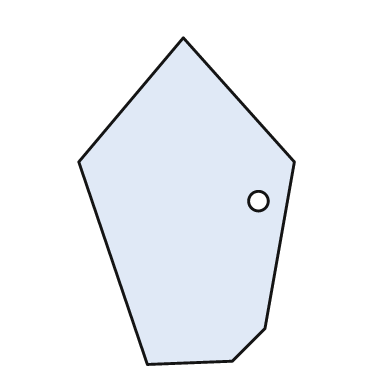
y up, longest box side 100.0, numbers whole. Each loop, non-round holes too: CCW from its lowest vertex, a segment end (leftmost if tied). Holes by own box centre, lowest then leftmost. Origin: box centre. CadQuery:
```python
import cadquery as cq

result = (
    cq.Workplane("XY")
    .moveTo(-12.0, -50.0)
    .lineTo(14.0, -49.0)
    .lineTo(24.0, -39.0)
    .lineTo(33.0, 12.0)
    .lineTo(-1.0, 50.0)
    .lineTo(-33.0, 12.0)
    .close()
    .moveTo(22.0, 0.0)
    .circle(3.0)
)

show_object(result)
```